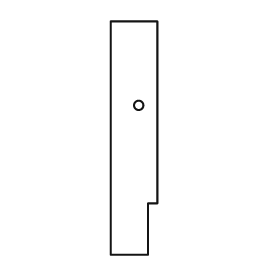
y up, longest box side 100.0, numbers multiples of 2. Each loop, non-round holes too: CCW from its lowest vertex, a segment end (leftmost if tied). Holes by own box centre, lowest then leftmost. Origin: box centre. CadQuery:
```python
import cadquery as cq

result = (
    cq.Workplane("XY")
    .moveTo(-10.0, -50.0)
    .lineTo(6.0, -50.0)
    .lineTo(6.0, -28.0)
    .lineTo(10.0, -28.0)
    .lineTo(10.0, 50.0)
    .lineTo(-10.0, 50.0)
    .close()
    .moveTo(2.0, 14.0)
    .circle(2.0)
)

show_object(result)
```